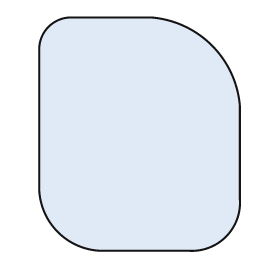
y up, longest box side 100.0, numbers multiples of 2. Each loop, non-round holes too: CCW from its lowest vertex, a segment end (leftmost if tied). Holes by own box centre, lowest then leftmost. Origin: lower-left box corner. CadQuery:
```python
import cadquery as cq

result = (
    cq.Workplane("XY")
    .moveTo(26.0, 0.0)
    .lineTo(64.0, 0.0)
    .threePointArc((80.0, 6.0), (86.0, 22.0))
    .lineTo(86.0, 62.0)
    .threePointArc((74.0, 88.0), (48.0, 100.0))
    .lineTo(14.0, 100.0)
    .threePointArc((4.0, 96.0), (0.0, 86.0))
    .lineTo(0.0, 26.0)
    .threePointArc((8.0, 8.0), (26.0, 0.0))
    .close()
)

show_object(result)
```